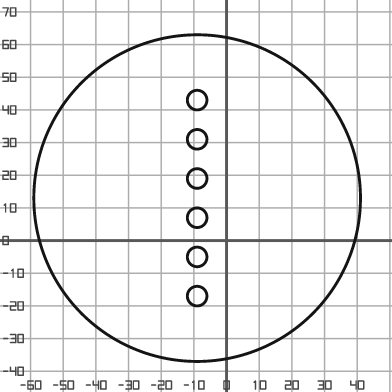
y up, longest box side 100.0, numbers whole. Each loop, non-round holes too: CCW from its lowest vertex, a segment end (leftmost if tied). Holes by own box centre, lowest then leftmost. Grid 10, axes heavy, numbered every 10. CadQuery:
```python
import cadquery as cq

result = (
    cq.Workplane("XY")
    .moveTo(-9.0, 13.0)
    .circle(50.0)
    .moveTo(-9.0, -17.0)
    .circle(3.0)
    .moveTo(-9.0, -5.0)
    .circle(3.0)
    .moveTo(-9.0, 7.0)
    .circle(3.0)
    .moveTo(-9.0, 19.0)
    .circle(3.0)
    .moveTo(-9.0, 31.0)
    .circle(3.0)
    .moveTo(-9.0, 43.0)
    .circle(3.0)
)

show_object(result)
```